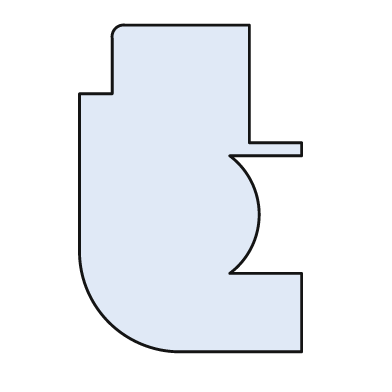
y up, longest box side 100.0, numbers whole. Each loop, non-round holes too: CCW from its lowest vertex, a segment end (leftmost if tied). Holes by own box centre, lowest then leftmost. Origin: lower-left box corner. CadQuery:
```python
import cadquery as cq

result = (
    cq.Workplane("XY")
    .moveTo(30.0, 0.0)
    .lineTo(68.0, 0.0)
    .lineTo(68.0, 24.0)
    .lineTo(46.0, 24.0)
    .threePointArc((55.0, 42.0), (46.0, 60.0))
    .lineTo(68.0, 60.0)
    .lineTo(68.0, 64.0)
    .lineTo(52.0, 64.0)
    .lineTo(52.0, 100.0)
    .lineTo(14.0, 100.0)
    .threePointArc((11.0, 99.0), (10.0, 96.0))
    .lineTo(10.0, 79.0)
    .lineTo(0.0, 79.0)
    .lineTo(0.0, 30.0)
    .threePointArc((9.0, 9.0), (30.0, 0.0))
    .close()
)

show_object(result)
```